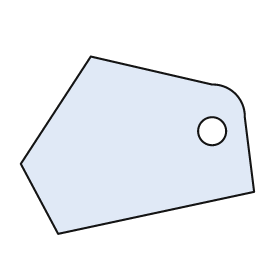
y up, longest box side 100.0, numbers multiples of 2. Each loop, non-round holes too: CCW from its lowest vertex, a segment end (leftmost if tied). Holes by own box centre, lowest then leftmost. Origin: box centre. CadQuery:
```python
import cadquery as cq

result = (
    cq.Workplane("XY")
    .moveTo(-34.0, -38.0)
    .lineTo(50.0, -20.0)
    .lineTo(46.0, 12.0)
    .threePointArc((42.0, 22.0), (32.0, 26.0))
    .lineTo(-20.0, 38.0)
    .lineTo(-50.0, -8.0)
    .close()
    .moveTo(32.0, 6.0)
    .circle(6.0)
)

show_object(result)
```